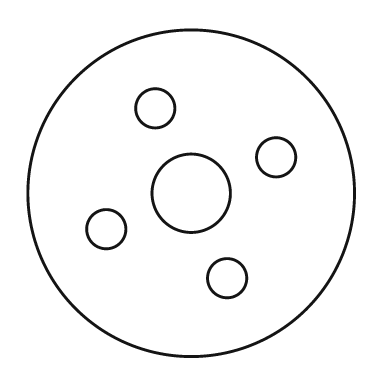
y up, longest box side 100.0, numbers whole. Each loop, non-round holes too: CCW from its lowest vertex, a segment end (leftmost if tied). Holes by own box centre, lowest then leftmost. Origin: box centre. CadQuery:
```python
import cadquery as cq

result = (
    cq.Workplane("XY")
    .moveTo(0.0, 0.0)
    .circle(50.0)
    .moveTo(11.0, -26.0)
    .circle(6.0)
    .moveTo(-26.0, -11.0)
    .circle(6.0)
    .moveTo(0.0, 0.0)
    .circle(12.0)
    .moveTo(26.0, 11.0)
    .circle(6.0)
    .moveTo(-11.0, 26.0)
    .circle(6.0)
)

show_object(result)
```